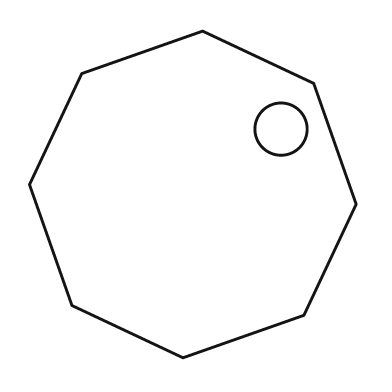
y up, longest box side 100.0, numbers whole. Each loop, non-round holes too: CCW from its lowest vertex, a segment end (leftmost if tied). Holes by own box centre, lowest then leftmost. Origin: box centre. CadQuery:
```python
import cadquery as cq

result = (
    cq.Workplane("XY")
    .moveTo(-3.0, -50.0)
    .lineTo(34.0, -37.0)
    .lineTo(50.0, -3.0)
    .lineTo(37.0, 34.0)
    .lineTo(3.0, 50.0)
    .lineTo(-34.0, 37.0)
    .lineTo(-50.0, 3.0)
    .lineTo(-37.0, -34.0)
    .close()
    .moveTo(27.0, 20.0)
    .circle(8.0)
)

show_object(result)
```